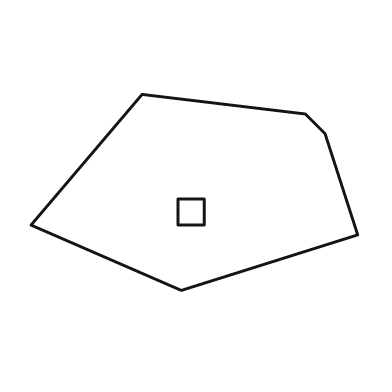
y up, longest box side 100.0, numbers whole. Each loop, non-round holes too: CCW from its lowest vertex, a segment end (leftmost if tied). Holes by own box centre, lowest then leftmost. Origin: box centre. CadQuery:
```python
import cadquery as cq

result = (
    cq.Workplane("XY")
    .moveTo(-4.0, -30.0)
    .lineTo(50.0, -13.0)
    .lineTo(40.0, 18.0)
    .lineTo(34.0, 24.0)
    .lineTo(-16.0, 30.0)
    .lineTo(-50.0, -10.0)
    .close()
    .moveTo(-5.0, -10.0)
    .lineTo(3.0, -10.0)
    .lineTo(3.0, -2.0)
    .lineTo(-5.0, -2.0)
    .close()
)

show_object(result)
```